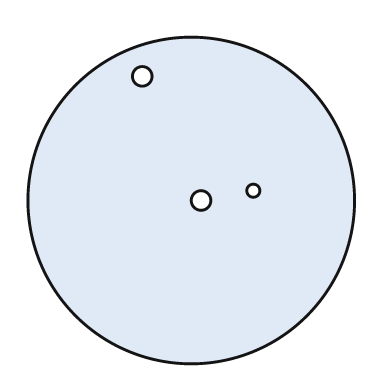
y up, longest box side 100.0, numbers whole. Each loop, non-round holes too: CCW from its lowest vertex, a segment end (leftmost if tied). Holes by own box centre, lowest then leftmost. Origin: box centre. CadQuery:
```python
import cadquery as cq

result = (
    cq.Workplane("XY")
    .moveTo(0.0, 0.0)
    .circle(50.0)
    .moveTo(3.0, 0.0)
    .circle(3.0)
    .moveTo(19.0, 3.0)
    .circle(2.0)
    .moveTo(-15.0, 38.0)
    .circle(3.0)
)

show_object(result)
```